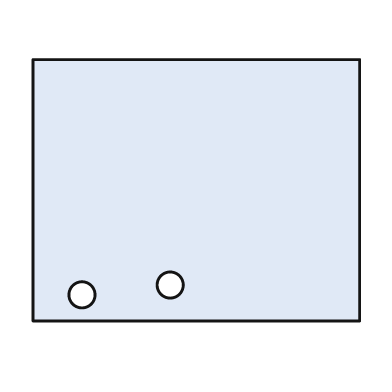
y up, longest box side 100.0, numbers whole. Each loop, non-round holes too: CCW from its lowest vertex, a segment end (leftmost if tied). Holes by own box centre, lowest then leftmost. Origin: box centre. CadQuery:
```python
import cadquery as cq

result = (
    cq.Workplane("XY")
    .moveTo(-50.0, -40.0)
    .lineTo(50.0, -40.0)
    .lineTo(50.0, 40.0)
    .lineTo(-50.0, 40.0)
    .close()
    .moveTo(-35.0, -32.0)
    .circle(4.0)
    .moveTo(-8.0, -29.0)
    .circle(4.0)
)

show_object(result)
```